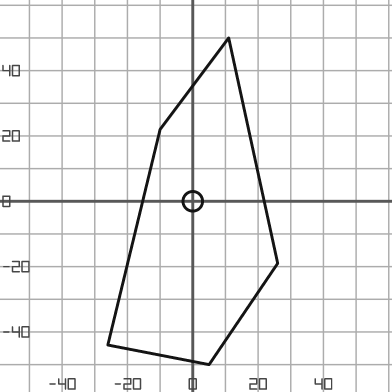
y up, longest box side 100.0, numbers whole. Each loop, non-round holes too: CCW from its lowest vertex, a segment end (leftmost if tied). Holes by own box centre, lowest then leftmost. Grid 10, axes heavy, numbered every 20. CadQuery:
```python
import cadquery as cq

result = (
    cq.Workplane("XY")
    .moveTo(5.0, -50.0)
    .lineTo(26.0, -19.0)
    .lineTo(11.0, 50.0)
    .lineTo(-10.0, 22.0)
    .lineTo(-26.0, -44.0)
    .close()
    .moveTo(0.0, 0.0)
    .circle(3.0)
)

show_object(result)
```